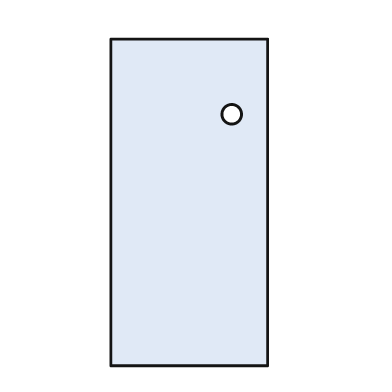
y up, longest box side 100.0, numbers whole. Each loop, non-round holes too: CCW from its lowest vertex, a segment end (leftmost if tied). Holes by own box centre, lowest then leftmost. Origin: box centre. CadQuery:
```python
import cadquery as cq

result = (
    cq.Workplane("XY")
    .moveTo(-24.0, -50.0)
    .lineTo(24.0, -50.0)
    .lineTo(24.0, 50.0)
    .lineTo(-24.0, 50.0)
    .close()
    .moveTo(13.0, 27.0)
    .circle(3.0)
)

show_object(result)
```